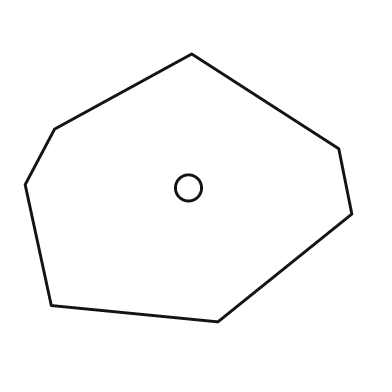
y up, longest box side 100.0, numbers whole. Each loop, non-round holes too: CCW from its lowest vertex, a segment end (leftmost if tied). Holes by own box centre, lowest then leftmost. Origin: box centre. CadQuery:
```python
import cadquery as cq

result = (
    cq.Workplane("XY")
    .moveTo(9.0, -41.0)
    .lineTo(50.0, -8.0)
    .lineTo(46.0, 12.0)
    .lineTo(1.0, 41.0)
    .lineTo(-41.0, 18.0)
    .lineTo(-50.0, 1.0)
    .lineTo(-42.0, -36.0)
    .close()
    .moveTo(0.0, 0.0)
    .circle(4.0)
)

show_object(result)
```